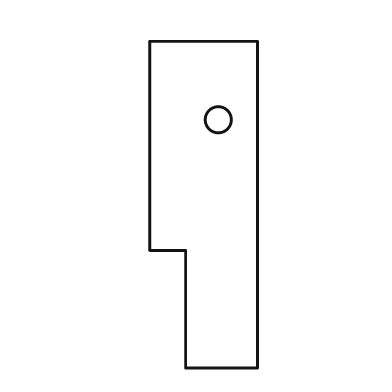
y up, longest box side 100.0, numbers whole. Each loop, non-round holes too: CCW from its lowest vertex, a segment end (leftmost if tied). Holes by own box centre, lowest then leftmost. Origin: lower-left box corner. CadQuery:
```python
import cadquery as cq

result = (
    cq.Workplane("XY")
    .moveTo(11.0, 0.0)
    .lineTo(33.0, 0.0)
    .lineTo(33.0, 100.0)
    .lineTo(0.0, 100.0)
    .lineTo(0.0, 36.0)
    .lineTo(11.0, 36.0)
    .close()
    .moveTo(21.0, 76.0)
    .circle(4.0)
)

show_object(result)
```